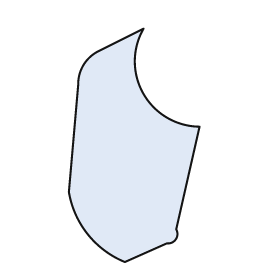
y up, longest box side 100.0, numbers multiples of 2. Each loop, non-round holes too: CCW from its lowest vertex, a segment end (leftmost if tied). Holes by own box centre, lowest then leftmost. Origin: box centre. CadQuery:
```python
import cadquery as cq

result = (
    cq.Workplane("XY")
    .moveTo(-4.0, -50.0)
    .lineTo(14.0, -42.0)
    .threePointArc((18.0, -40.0), (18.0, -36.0))
    .lineTo(28.0, 8.0)
    .threePointArc((4.0, 22.0), (4.0, 50.0))
    .lineTo(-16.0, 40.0)
    .threePointArc((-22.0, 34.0), (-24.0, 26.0))
    .lineTo(-28.0, -20.0)
    .threePointArc((-20.0, -38.0), (-4.0, -50.0))
    .close()
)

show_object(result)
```